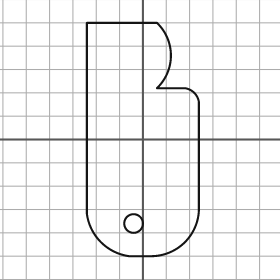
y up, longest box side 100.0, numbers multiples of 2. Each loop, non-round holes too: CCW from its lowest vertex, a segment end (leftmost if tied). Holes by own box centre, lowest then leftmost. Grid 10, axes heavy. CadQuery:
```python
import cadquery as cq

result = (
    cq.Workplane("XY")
    .moveTo(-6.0, -50.0)
    .lineTo(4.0, -50.0)
    .threePointArc((18.0, -44.0), (24.0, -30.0))
    .lineTo(24.0, 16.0)
    .threePointArc((22.0, 20.0), (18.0, 22.0))
    .lineTo(6.0, 22.0)
    .threePointArc((12.0, 36.0), (6.0, 50.0))
    .lineTo(-24.0, 50.0)
    .lineTo(-24.0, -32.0)
    .threePointArc((-18.0, -44.0), (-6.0, -50.0))
    .close()
    .moveTo(-4.0, -36.0)
    .circle(4.0)
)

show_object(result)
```